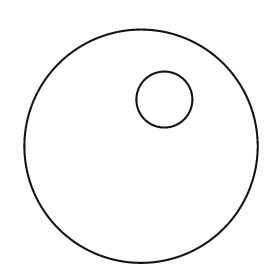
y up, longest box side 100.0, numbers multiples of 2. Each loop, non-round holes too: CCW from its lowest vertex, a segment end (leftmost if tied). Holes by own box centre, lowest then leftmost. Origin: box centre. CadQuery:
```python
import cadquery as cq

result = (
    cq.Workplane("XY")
    .moveTo(0.0, 0.0)
    .circle(50.0)
    .moveTo(10.0, 20.0)
    .circle(12.0)
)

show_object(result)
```